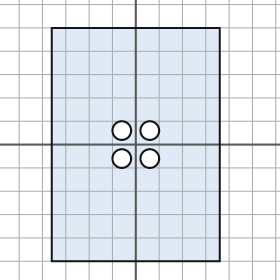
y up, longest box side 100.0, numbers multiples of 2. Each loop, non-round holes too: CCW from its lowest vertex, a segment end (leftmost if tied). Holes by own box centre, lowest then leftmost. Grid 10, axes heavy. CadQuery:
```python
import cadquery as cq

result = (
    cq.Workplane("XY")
    .moveTo(-36.0, -50.0)
    .lineTo(36.0, -50.0)
    .lineTo(36.0, 50.0)
    .lineTo(-36.0, 50.0)
    .close()
    .moveTo(-6.0, -6.0)
    .circle(4.0)
    .moveTo(6.0, -6.0)
    .circle(4.0)
    .moveTo(-6.0, 6.0)
    .circle(4.0)
    .moveTo(6.0, 6.0)
    .circle(4.0)
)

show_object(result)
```